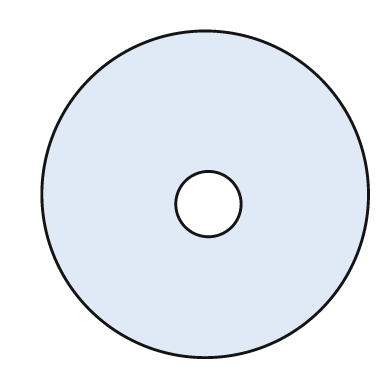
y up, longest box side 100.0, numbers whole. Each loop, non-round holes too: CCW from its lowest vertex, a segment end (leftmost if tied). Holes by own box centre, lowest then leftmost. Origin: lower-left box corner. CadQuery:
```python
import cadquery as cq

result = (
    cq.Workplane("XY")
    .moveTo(50.0, 50.0)
    .circle(50.0)
    .moveTo(51.0, 47.0)
    .circle(10.0)
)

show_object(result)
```